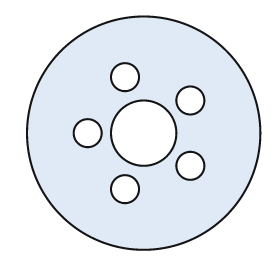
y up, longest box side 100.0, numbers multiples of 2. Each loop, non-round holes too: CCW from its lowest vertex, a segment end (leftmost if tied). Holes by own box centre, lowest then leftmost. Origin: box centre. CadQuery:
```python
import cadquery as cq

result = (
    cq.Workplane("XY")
    .moveTo(0.0, 0.0)
    .circle(50.0)
    .moveTo(-8.0, -24.0)
    .circle(6.0)
    .moveTo(20.0, -14.0)
    .circle(6.0)
    .moveTo(-24.0, 0.0)
    .circle(6.0)
    .moveTo(0.0, 0.0)
    .circle(14.0)
    .moveTo(20.0, 14.0)
    .circle(6.0)
    .moveTo(-8.0, 24.0)
    .circle(6.0)
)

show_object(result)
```